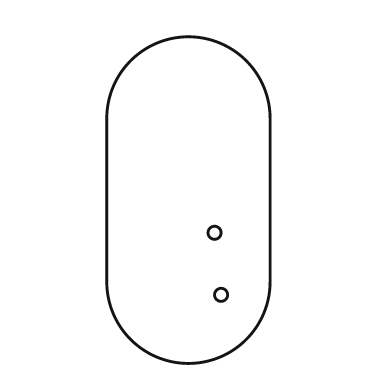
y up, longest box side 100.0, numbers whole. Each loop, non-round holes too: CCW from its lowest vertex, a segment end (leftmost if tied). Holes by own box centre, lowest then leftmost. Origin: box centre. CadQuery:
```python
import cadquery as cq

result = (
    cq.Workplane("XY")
    .moveTo(-25.0, -25.0)
    .threePointArc((0.0, -50.0), (25.0, -25.0))
    .lineTo(25.0, 25.0)
    .threePointArc((0.0, 50.0), (-25.0, 25.0))
    .close()
    .moveTo(10.0, -29.0)
    .circle(2.0)
    .moveTo(8.0, -10.0)
    .circle(2.0)
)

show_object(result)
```